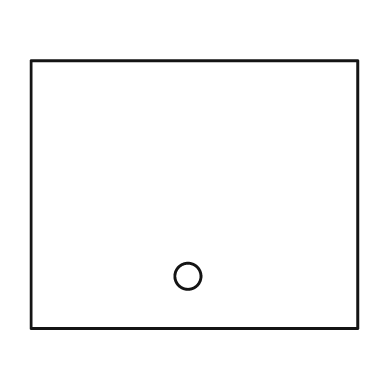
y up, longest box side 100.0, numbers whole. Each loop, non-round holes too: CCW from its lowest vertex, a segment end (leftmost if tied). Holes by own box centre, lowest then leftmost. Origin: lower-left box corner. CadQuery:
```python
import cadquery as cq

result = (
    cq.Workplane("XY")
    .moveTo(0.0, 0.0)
    .lineTo(100.0, 0.0)
    .lineTo(100.0, 82.0)
    .lineTo(0.0, 82.0)
    .close()
    .moveTo(48.0, 16.0)
    .circle(4.0)
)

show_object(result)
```